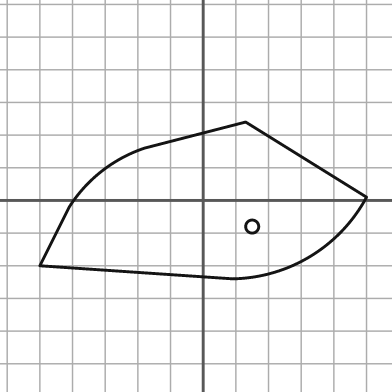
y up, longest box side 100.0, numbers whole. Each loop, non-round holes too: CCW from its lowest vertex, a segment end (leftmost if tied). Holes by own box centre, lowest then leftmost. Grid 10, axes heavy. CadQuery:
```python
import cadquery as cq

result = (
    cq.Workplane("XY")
    .moveTo(9.0, -24.0)
    .threePointArc((33.0, -17.0), (50.0, 1.0))
    .lineTo(13.0, 24.0)
    .lineTo(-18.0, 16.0)
    .threePointArc((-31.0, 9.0), (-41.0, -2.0))
    .lineTo(-50.0, -20.0)
    .close()
    .moveTo(15.0, -8.0)
    .circle(2.0)
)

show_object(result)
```